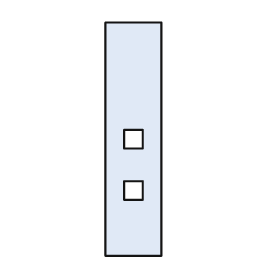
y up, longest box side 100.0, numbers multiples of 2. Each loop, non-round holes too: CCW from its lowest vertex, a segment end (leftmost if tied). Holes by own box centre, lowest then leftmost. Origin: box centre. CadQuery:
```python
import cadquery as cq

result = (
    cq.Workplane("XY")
    .moveTo(-12.0, -50.0)
    .lineTo(12.0, -50.0)
    .lineTo(12.0, 50.0)
    .lineTo(-12.0, 50.0)
    .close()
    .moveTo(-4.0, -26.0)
    .lineTo(4.0, -26.0)
    .lineTo(4.0, -18.0)
    .lineTo(-4.0, -18.0)
    .close()
    .moveTo(-4.0, -4.0)
    .lineTo(4.0, -4.0)
    .lineTo(4.0, 4.0)
    .lineTo(-4.0, 4.0)
    .close()
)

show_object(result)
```